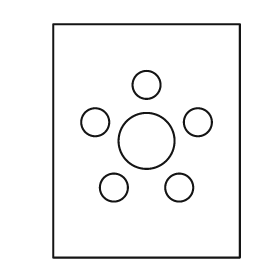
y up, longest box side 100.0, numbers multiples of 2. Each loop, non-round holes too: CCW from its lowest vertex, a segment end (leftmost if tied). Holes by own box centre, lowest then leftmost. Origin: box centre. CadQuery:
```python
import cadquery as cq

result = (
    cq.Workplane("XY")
    .moveTo(-40.0, -50.0)
    .lineTo(40.0, -50.0)
    .lineTo(40.0, 50.0)
    .lineTo(-40.0, 50.0)
    .close()
    .moveTo(-14.0, -20.0)
    .circle(6.0)
    .moveTo(14.0, -20.0)
    .circle(6.0)
    .moveTo(0.0, 0.0)
    .circle(12.0)
    .moveTo(-22.0, 8.0)
    .circle(6.0)
    .moveTo(22.0, 8.0)
    .circle(6.0)
    .moveTo(0.0, 24.0)
    .circle(6.0)
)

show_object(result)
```